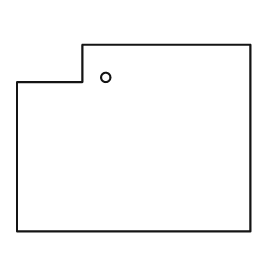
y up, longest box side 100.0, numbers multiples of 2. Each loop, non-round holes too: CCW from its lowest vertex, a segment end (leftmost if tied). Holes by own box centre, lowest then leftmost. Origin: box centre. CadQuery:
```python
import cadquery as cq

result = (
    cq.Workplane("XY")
    .moveTo(-50.0, -40.0)
    .lineTo(50.0, -40.0)
    .lineTo(50.0, 40.0)
    .lineTo(-22.0, 40.0)
    .lineTo(-22.0, 24.0)
    .lineTo(-50.0, 24.0)
    .close()
    .moveTo(-12.0, 26.0)
    .circle(2.0)
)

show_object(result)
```